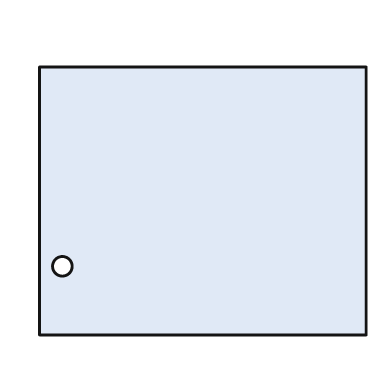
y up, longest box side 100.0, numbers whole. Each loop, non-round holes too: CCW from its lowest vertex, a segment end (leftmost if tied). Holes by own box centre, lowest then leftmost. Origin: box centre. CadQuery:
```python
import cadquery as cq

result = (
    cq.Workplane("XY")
    .moveTo(-50.0, -41.0)
    .lineTo(50.0, -41.0)
    .lineTo(50.0, 41.0)
    .lineTo(-50.0, 41.0)
    .close()
    .moveTo(-43.0, -20.0)
    .circle(3.0)
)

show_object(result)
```